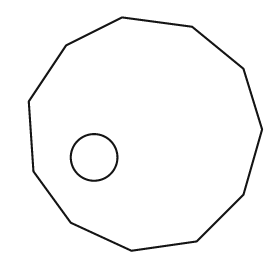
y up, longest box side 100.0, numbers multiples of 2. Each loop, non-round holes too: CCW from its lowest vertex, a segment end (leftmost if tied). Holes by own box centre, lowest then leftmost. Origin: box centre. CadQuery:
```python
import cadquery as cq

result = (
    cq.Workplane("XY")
    .moveTo(-6.0, -50.0)
    .lineTo(22.0, -46.0)
    .lineTo(42.0, -26.0)
    .lineTo(50.0, 2.0)
    .lineTo(42.0, 28.0)
    .lineTo(20.0, 46.0)
    .lineTo(-10.0, 50.0)
    .lineTo(-34.0, 38.0)
    .lineTo(-50.0, 14.0)
    .lineTo(-48.0, -16.0)
    .lineTo(-32.0, -38.0)
    .close()
    .moveTo(-22.0, -10.0)
    .circle(10.0)
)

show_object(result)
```